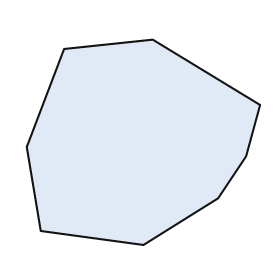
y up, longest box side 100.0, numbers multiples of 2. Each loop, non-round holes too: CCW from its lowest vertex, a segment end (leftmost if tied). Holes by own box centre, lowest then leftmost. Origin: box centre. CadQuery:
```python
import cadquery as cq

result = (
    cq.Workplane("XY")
    .moveTo(0.0, -44.0)
    .lineTo(32.0, -24.0)
    .lineTo(44.0, -6.0)
    .lineTo(50.0, 16.0)
    .lineTo(4.0, 44.0)
    .lineTo(-34.0, 40.0)
    .lineTo(-50.0, -2.0)
    .lineTo(-44.0, -38.0)
    .close()
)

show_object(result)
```